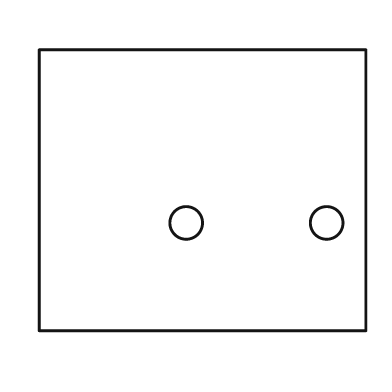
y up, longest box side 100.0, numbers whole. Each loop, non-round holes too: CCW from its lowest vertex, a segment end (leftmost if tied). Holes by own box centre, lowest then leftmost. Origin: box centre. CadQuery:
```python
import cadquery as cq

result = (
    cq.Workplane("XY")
    .moveTo(-50.0, -43.0)
    .lineTo(50.0, -43.0)
    .lineTo(50.0, 43.0)
    .lineTo(-50.0, 43.0)
    .close()
    .moveTo(-5.0, -10.0)
    .circle(5.0)
    .moveTo(38.0, -10.0)
    .circle(5.0)
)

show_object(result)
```